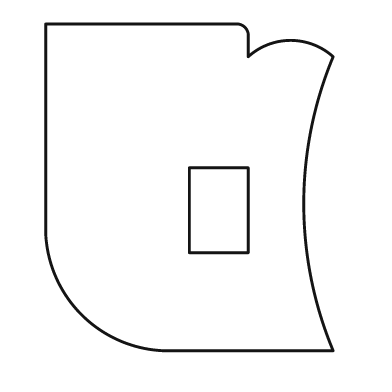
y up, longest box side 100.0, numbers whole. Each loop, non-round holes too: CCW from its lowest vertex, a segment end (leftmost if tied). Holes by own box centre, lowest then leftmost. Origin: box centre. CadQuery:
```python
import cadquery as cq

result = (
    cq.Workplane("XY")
    .moveTo(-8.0, -50.0)
    .lineTo(44.0, -50.0)
    .threePointArc((35.0, -5.0), (44.0, 40.0))
    .threePointArc((31.0, 45.0), (18.0, 40.0))
    .lineTo(18.0, 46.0)
    .threePointArc((17.0, 49.0), (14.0, 50.0))
    .lineTo(-44.0, 50.0)
    .lineTo(-44.0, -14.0)
    .threePointArc((-33.0, -39.0), (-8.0, -50.0))
    .close()
    .moveTo(0.0, -20.0)
    .lineTo(18.0, -20.0)
    .lineTo(18.0, 6.0)
    .lineTo(0.0, 6.0)
    .close()
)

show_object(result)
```